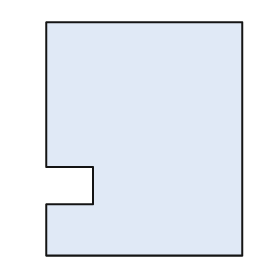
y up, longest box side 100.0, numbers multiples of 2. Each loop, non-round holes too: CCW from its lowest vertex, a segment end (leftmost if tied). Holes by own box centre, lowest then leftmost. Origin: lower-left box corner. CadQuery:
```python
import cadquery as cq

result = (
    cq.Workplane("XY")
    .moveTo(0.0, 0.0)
    .lineTo(84.0, 0.0)
    .lineTo(84.0, 100.0)
    .lineTo(0.0, 100.0)
    .lineTo(0.0, 38.0)
    .lineTo(20.0, 38.0)
    .lineTo(20.0, 22.0)
    .lineTo(0.0, 22.0)
    .close()
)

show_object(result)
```